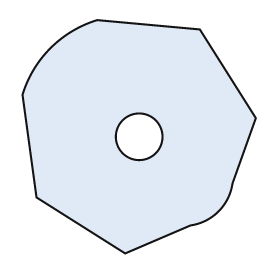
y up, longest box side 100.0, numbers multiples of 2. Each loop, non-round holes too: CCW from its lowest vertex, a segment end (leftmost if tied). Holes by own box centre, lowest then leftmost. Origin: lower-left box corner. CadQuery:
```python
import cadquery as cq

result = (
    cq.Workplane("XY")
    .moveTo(44.0, 0.0)
    .lineTo(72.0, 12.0)
    .threePointArc((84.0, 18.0), (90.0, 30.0))
    .lineTo(100.0, 58.0)
    .lineTo(76.0, 96.0)
    .lineTo(32.0, 100.0)
    .threePointArc((12.0, 88.0), (0.0, 68.0))
    .lineTo(6.0, 24.0)
    .close()
    .moveTo(50.0, 50.0)
    .circle(10.0)
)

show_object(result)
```